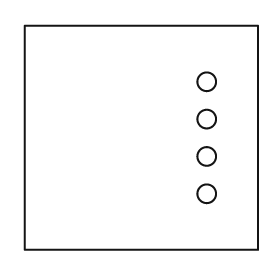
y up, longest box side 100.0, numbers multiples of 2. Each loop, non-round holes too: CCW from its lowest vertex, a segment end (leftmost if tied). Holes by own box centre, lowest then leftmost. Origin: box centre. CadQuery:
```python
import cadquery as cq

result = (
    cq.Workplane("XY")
    .moveTo(-50.0, -48.0)
    .lineTo(50.0, -48.0)
    .lineTo(50.0, 48.0)
    .lineTo(-50.0, 48.0)
    .close()
    .moveTo(28.0, -24.0)
    .circle(4.0)
    .moveTo(28.0, -8.0)
    .circle(4.0)
    .moveTo(28.0, 8.0)
    .circle(4.0)
    .moveTo(28.0, 24.0)
    .circle(4.0)
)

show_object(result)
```